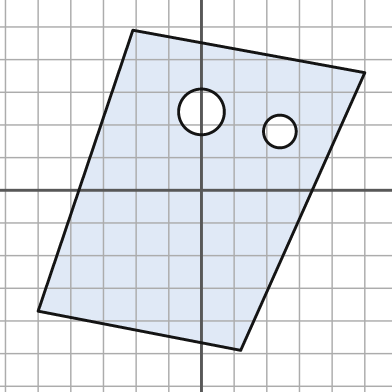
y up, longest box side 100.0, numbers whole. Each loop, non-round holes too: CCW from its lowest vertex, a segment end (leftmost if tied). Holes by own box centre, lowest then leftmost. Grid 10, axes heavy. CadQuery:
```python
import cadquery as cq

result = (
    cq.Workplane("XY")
    .moveTo(12.0, -49.0)
    .lineTo(50.0, 36.0)
    .lineTo(-21.0, 49.0)
    .lineTo(-50.0, -37.0)
    .close()
    .moveTo(24.0, 18.0)
    .circle(5.0)
    .moveTo(0.0, 24.0)
    .circle(7.0)
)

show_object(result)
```